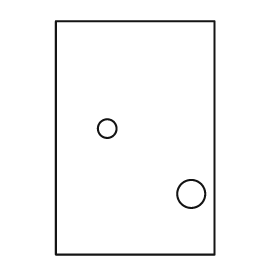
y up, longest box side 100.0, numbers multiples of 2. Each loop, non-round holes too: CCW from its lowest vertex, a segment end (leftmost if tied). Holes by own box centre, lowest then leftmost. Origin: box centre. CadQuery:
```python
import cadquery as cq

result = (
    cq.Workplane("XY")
    .moveTo(-34.0, -50.0)
    .lineTo(34.0, -50.0)
    .lineTo(34.0, 50.0)
    .lineTo(-34.0, 50.0)
    .close()
    .moveTo(24.0, -24.0)
    .circle(6.0)
    .moveTo(-12.0, 4.0)
    .circle(4.0)
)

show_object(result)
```